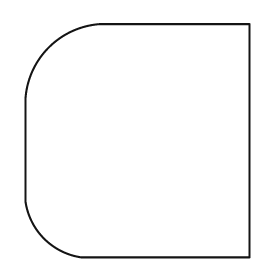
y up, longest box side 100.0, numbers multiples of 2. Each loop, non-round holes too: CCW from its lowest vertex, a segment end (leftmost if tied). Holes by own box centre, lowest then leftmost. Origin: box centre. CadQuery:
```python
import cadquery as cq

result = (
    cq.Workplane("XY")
    .moveTo(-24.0, -50.0)
    .lineTo(48.0, -50.0)
    .lineTo(48.0, 50.0)
    .lineTo(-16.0, 50.0)
    .threePointArc((-38.0, 40.0), (-48.0, 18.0))
    .lineTo(-48.0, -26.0)
    .threePointArc((-40.0, -42.0), (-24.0, -50.0))
    .close()
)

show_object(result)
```